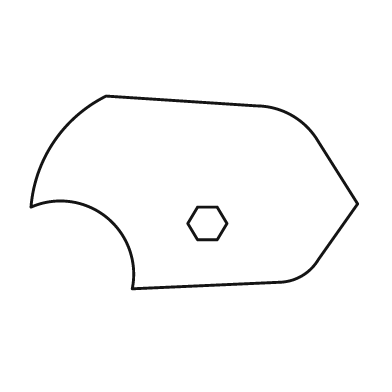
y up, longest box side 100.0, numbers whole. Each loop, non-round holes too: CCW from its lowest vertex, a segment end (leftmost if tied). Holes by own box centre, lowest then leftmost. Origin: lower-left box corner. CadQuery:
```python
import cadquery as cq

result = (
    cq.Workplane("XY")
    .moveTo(31.0, 0.0)
    .lineTo(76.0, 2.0)
    .threePointArc((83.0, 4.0), (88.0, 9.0))
    .lineTo(100.0, 26.0)
    .lineTo(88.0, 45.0)
    .threePointArc((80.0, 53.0), (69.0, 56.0))
    .lineTo(23.0, 59.0)
    .threePointArc((7.0, 45.0), (0.0, 25.0))
    .threePointArc((23.0, 22.0), (31.0, 0.0))
    .close()
    .moveTo(51.0, 15.0)
    .lineTo(57.0, 15.0)
    .lineTo(60.0, 20.0)
    .lineTo(57.0, 25.0)
    .lineTo(51.0, 25.0)
    .lineTo(48.0, 20.0)
    .close()
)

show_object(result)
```